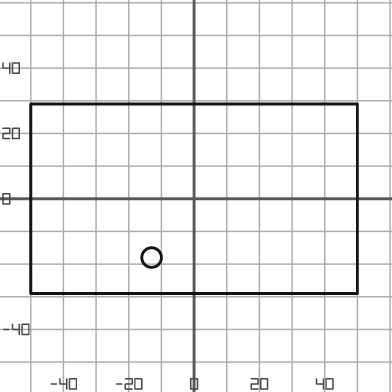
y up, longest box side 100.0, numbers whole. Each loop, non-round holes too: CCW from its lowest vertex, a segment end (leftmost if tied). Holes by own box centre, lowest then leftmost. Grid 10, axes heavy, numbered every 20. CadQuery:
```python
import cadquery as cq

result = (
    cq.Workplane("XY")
    .moveTo(-50.0, -29.0)
    .lineTo(50.0, -29.0)
    .lineTo(50.0, 29.0)
    .lineTo(-50.0, 29.0)
    .close()
    .moveTo(-13.0, -18.0)
    .circle(3.0)
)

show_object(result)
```